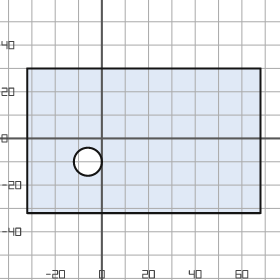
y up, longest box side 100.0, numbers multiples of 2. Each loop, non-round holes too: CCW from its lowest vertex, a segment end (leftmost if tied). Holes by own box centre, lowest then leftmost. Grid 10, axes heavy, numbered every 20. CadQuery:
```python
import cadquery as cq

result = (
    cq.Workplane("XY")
    .moveTo(-32.0, -32.0)
    .lineTo(68.0, -32.0)
    .lineTo(68.0, 30.0)
    .lineTo(-32.0, 30.0)
    .close()
    .moveTo(-6.0, -10.0)
    .circle(6.0)
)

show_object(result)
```